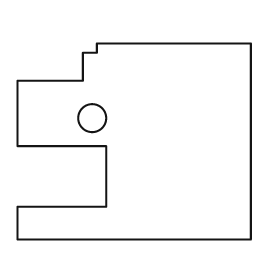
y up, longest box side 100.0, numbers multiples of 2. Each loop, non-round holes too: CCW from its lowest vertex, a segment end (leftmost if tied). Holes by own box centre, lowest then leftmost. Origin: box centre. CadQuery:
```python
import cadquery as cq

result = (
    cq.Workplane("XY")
    .moveTo(-50.0, -42.0)
    .lineTo(50.0, -42.0)
    .lineTo(50.0, 42.0)
    .lineTo(-16.0, 42.0)
    .lineTo(-16.0, 38.0)
    .lineTo(-22.0, 38.0)
    .lineTo(-22.0, 26.0)
    .lineTo(-50.0, 26.0)
    .lineTo(-50.0, -2.0)
    .lineTo(-12.0, -2.0)
    .lineTo(-12.0, -28.0)
    .lineTo(-50.0, -28.0)
    .close()
    .moveTo(-18.0, 10.0)
    .circle(6.0)
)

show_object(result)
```